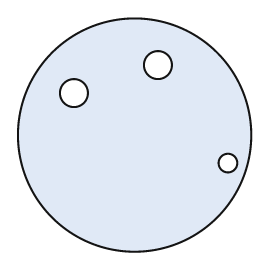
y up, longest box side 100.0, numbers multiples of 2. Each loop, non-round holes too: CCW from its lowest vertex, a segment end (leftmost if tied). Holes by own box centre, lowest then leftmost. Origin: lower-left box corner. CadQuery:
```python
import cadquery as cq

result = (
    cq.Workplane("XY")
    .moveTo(50.0, 50.0)
    .circle(50.0)
    .moveTo(90.0, 38.0)
    .circle(4.0)
    .moveTo(24.0, 68.0)
    .circle(6.0)
    .moveTo(60.0, 80.0)
    .circle(6.0)
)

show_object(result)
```